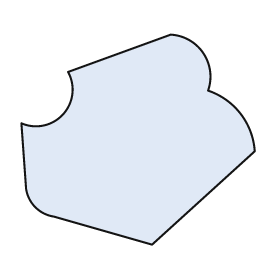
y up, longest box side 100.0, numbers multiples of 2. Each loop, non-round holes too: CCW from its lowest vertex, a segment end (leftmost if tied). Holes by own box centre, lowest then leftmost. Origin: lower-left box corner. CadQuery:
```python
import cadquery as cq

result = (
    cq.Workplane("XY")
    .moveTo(56.0, 0.0)
    .lineTo(100.0, 40.0)
    .threePointArc((94.0, 56.0), (80.0, 66.0))
    .threePointArc((78.0, 82.0), (64.0, 90.0))
    .lineTo(20.0, 74.0)
    .threePointArc((18.0, 56.0), (0.0, 52.0))
    .lineTo(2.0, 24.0)
    .threePointArc((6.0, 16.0), (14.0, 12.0))
    .close()
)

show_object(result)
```